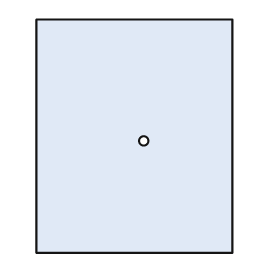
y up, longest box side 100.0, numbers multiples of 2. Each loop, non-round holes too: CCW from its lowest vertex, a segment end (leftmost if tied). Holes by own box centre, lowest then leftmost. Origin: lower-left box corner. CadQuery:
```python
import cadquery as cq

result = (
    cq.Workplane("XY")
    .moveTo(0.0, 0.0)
    .lineTo(84.0, 0.0)
    .lineTo(84.0, 100.0)
    .lineTo(0.0, 100.0)
    .close()
    .moveTo(46.0, 48.0)
    .circle(2.0)
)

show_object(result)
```